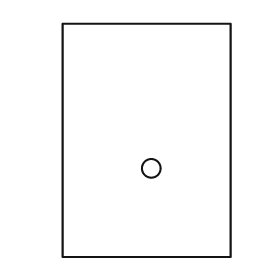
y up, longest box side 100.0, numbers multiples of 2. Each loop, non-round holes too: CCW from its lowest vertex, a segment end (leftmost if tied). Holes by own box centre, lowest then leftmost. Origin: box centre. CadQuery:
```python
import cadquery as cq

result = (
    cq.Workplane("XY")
    .moveTo(-36.0, -50.0)
    .lineTo(36.0, -50.0)
    .lineTo(36.0, 50.0)
    .lineTo(-36.0, 50.0)
    .close()
    .moveTo(2.0, -12.0)
    .circle(4.0)
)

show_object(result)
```